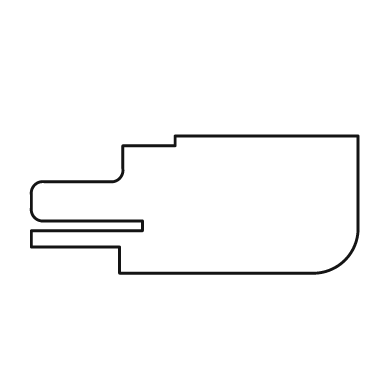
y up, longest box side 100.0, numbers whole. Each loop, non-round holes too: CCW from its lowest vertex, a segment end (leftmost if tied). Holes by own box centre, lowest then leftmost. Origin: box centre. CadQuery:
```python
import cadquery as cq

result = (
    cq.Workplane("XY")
    .moveTo(-23.0, -21.0)
    .lineTo(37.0, -21.0)
    .threePointArc((46.0, -17.0), (50.0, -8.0))
    .lineTo(50.0, 21.0)
    .lineTo(-6.0, 21.0)
    .lineTo(-6.0, 18.0)
    .lineTo(-22.0, 18.0)
    .lineTo(-22.0, 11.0)
    .threePointArc((-23.0, 8.0), (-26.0, 7.0))
    .lineTo(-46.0, 7.0)
    .threePointArc((-49.0, 6.0), (-50.0, 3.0))
    .lineTo(-50.0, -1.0)
    .threePointArc((-49.0, -4.0), (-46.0, -5.0))
    .lineTo(-16.0, -5.0)
    .lineTo(-16.0, -8.0)
    .lineTo(-50.0, -8.0)
    .lineTo(-50.0, -13.0)
    .lineTo(-23.0, -13.0)
    .close()
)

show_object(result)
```